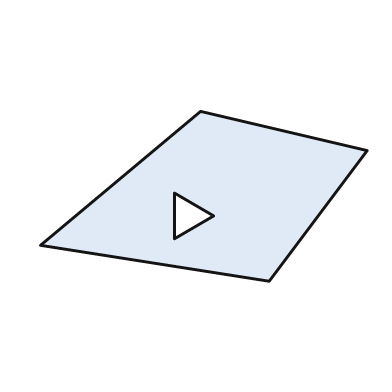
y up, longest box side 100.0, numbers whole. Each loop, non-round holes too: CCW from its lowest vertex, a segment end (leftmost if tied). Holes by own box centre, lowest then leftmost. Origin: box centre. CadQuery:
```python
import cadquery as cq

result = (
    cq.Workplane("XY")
    .moveTo(20.0, -26.0)
    .lineTo(50.0, 14.0)
    .lineTo(-1.0, 26.0)
    .lineTo(-50.0, -15.0)
    .close()
    .moveTo(-9.0, -13.0)
    .lineTo(3.0, -6.0)
    .lineTo(-9.0, 1.0)
    .close()
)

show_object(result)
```